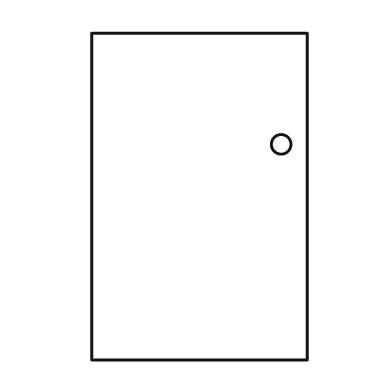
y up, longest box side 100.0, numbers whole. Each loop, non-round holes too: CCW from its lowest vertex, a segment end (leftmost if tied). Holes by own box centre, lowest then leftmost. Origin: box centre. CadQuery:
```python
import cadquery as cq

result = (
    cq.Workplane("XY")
    .moveTo(-33.0, -50.0)
    .lineTo(33.0, -50.0)
    .lineTo(33.0, 50.0)
    .lineTo(-33.0, 50.0)
    .close()
    .moveTo(25.0, 16.0)
    .circle(3.0)
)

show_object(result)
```